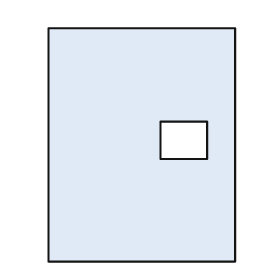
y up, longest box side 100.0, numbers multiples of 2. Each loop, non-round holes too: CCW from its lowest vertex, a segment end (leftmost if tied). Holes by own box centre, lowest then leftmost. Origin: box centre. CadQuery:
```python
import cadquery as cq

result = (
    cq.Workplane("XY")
    .moveTo(-40.0, -50.0)
    .lineTo(40.0, -50.0)
    .lineTo(40.0, 50.0)
    .lineTo(-40.0, 50.0)
    .close()
    .moveTo(8.0, -6.0)
    .lineTo(28.0, -6.0)
    .lineTo(28.0, 10.0)
    .lineTo(8.0, 10.0)
    .close()
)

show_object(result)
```